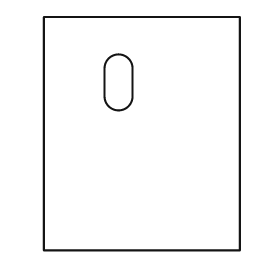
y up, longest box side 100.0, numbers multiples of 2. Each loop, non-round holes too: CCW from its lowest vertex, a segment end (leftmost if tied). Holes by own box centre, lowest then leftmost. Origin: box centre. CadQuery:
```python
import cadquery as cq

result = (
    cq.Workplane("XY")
    .moveTo(-42.0, -50.0)
    .lineTo(42.0, -50.0)
    .lineTo(42.0, 50.0)
    .lineTo(-42.0, 50.0)
    .close()
    .moveTo(-16.0, 16.0)
    .threePointArc((-10.0, 10.0), (-4.0, 16.0))
    .lineTo(-4.0, 28.0)
    .threePointArc((-10.0, 34.0), (-16.0, 28.0))
    .close()
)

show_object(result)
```